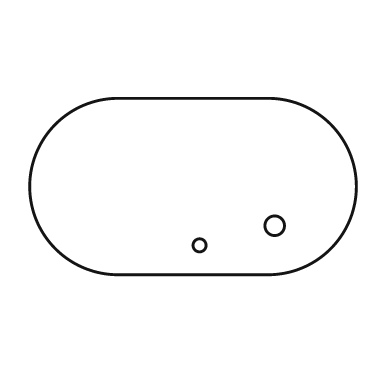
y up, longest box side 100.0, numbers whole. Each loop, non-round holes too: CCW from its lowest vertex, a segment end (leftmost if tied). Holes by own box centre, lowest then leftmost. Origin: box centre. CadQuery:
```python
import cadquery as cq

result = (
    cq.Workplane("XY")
    .moveTo(-23.0, -27.0)
    .lineTo(23.0, -27.0)
    .threePointArc((50.0, 0.0), (23.0, 27.0))
    .lineTo(-23.0, 27.0)
    .threePointArc((-50.0, 0.0), (-23.0, -27.0))
    .close()
    .moveTo(2.0, -18.0)
    .circle(2.0)
    .moveTo(25.0, -12.0)
    .circle(3.0)
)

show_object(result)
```